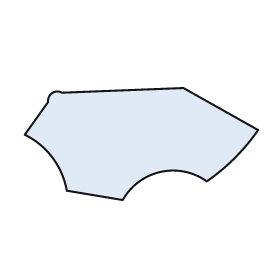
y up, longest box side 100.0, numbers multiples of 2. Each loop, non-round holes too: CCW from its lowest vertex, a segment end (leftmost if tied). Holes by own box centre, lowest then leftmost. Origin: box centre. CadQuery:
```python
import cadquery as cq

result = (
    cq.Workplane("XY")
    .moveTo(-8.0, -24.0)
    .threePointArc((8.0, -12.0), (28.0, -16.0))
    .threePointArc((40.0, -6.0), (50.0, 6.0))
    .lineTo(18.0, 24.0)
    .lineTo(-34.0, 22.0)
    .threePointArc((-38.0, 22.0), (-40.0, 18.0))
    .lineTo(-50.0, 4.0)
    .threePointArc((-38.0, -6.0), (-32.0, -20.0))
    .close()
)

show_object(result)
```